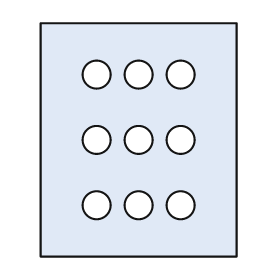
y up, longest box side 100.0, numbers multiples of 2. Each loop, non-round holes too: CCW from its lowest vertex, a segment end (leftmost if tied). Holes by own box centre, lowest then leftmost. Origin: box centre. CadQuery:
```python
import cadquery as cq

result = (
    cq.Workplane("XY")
    .moveTo(-42.0, -50.0)
    .lineTo(42.0, -50.0)
    .lineTo(42.0, 50.0)
    .lineTo(-42.0, 50.0)
    .close()
    .moveTo(-18.0, -28.0)
    .circle(6.0)
    .moveTo(0.0, -28.0)
    .circle(6.0)
    .moveTo(18.0, -28.0)
    .circle(6.0)
    .moveTo(-18.0, 0.0)
    .circle(6.0)
    .moveTo(0.0, 0.0)
    .circle(6.0)
    .moveTo(18.0, 0.0)
    .circle(6.0)
    .moveTo(-18.0, 28.0)
    .circle(6.0)
    .moveTo(0.0, 28.0)
    .circle(6.0)
    .moveTo(18.0, 28.0)
    .circle(6.0)
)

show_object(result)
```